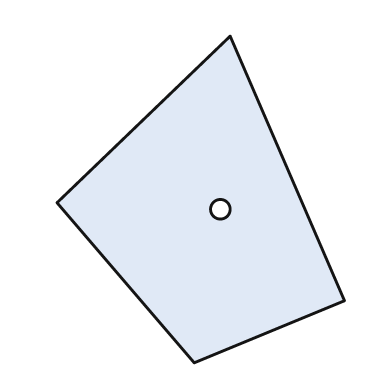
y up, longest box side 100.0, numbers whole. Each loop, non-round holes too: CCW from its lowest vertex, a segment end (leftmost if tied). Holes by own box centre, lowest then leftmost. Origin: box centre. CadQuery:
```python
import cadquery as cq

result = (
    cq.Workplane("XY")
    .moveTo(-2.0, -50.0)
    .lineTo(44.0, -31.0)
    .lineTo(9.0, 50.0)
    .lineTo(-44.0, -1.0)
    .close()
    .moveTo(6.0, -3.0)
    .circle(3.0)
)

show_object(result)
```